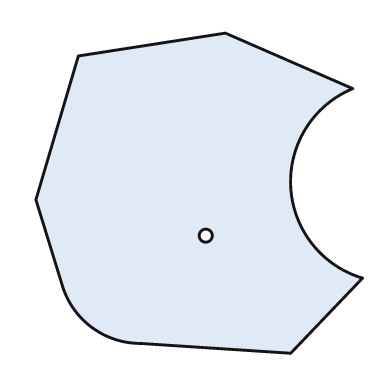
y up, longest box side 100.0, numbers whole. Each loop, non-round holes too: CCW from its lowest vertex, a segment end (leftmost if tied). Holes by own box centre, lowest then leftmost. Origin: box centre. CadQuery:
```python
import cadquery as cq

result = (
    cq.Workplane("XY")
    .moveTo(28.0, -49.0)
    .lineTo(50.0, -26.0)
    .threePointArc((28.0, 2.0), (47.0, 32.0))
    .lineTo(8.0, 49.0)
    .lineTo(-37.0, 42.0)
    .lineTo(-50.0, -2.0)
    .lineTo(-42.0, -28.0)
    .threePointArc((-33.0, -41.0), (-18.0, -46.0))
    .close()
    .moveTo(2.0, -13.0)
    .circle(2.0)
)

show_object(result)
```